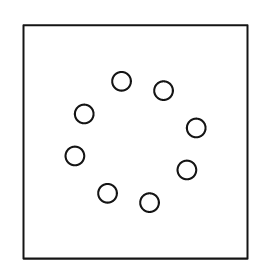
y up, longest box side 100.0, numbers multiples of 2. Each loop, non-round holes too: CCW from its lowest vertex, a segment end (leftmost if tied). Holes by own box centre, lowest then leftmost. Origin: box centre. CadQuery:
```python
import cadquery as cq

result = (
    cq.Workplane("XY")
    .moveTo(-48.0, -50.0)
    .lineTo(48.0, -50.0)
    .lineTo(48.0, 50.0)
    .lineTo(-48.0, 50.0)
    .close()
    .moveTo(6.0, -26.0)
    .circle(4.0)
    .moveTo(-12.0, -22.0)
    .circle(4.0)
    .moveTo(22.0, -12.0)
    .circle(4.0)
    .moveTo(-26.0, -6.0)
    .circle(4.0)
    .moveTo(26.0, 6.0)
    .circle(4.0)
    .moveTo(-22.0, 12.0)
    .circle(4.0)
    .moveTo(12.0, 22.0)
    .circle(4.0)
    .moveTo(-6.0, 26.0)
    .circle(4.0)
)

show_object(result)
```